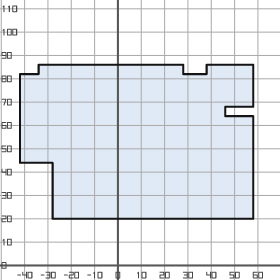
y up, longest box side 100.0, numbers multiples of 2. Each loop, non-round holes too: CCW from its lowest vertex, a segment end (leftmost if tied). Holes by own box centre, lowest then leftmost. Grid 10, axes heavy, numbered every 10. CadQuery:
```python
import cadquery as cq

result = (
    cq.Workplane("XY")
    .moveTo(-28.0, 20.0)
    .lineTo(58.0, 20.0)
    .lineTo(58.0, 64.0)
    .lineTo(46.0, 64.0)
    .lineTo(46.0, 68.0)
    .lineTo(58.0, 68.0)
    .lineTo(58.0, 86.0)
    .lineTo(38.0, 86.0)
    .lineTo(38.0, 82.0)
    .lineTo(28.0, 82.0)
    .lineTo(28.0, 86.0)
    .lineTo(-34.0, 86.0)
    .lineTo(-34.0, 82.0)
    .lineTo(-42.0, 82.0)
    .lineTo(-42.0, 44.0)
    .lineTo(-28.0, 44.0)
    .close()
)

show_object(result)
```